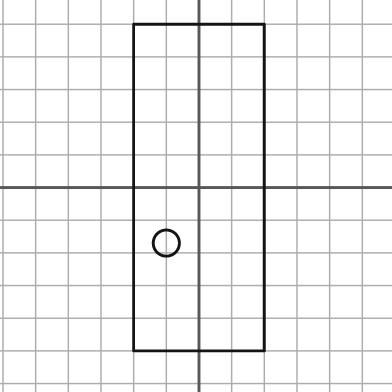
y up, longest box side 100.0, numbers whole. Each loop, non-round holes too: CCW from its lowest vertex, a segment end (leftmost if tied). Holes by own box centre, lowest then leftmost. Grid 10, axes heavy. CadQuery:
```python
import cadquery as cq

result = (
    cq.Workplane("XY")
    .moveTo(-20.0, -50.0)
    .lineTo(20.0, -50.0)
    .lineTo(20.0, 50.0)
    .lineTo(-20.0, 50.0)
    .close()
    .moveTo(-10.0, -17.0)
    .circle(4.0)
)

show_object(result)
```